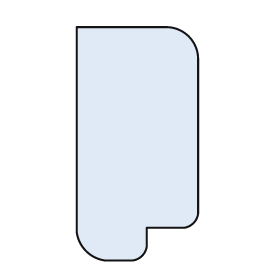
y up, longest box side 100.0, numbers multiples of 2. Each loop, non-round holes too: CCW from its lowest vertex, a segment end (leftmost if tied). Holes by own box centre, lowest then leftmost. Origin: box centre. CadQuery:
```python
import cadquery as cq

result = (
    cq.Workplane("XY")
    .moveTo(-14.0, -50.0)
    .lineTo(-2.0, -50.0)
    .threePointArc((2.0, -48.0), (4.0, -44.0))
    .lineTo(4.0, -36.0)
    .lineTo(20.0, -36.0)
    .threePointArc((24.0, -34.0), (26.0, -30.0))
    .lineTo(26.0, 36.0)
    .threePointArc((22.0, 46.0), (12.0, 50.0))
    .lineTo(-26.0, 50.0)
    .lineTo(-26.0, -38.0)
    .threePointArc((-22.0, -46.0), (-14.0, -50.0))
    .close()
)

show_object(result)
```